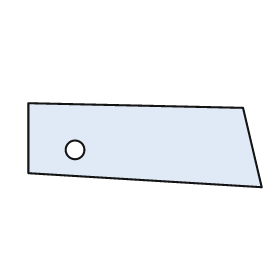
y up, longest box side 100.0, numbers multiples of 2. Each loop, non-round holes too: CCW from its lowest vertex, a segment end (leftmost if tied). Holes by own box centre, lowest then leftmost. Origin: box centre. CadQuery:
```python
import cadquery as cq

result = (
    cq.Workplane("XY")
    .moveTo(50.0, -18.0)
    .lineTo(42.0, 16.0)
    .lineTo(-50.0, 18.0)
    .lineTo(-50.0, -12.0)
    .close()
    .moveTo(-30.0, -2.0)
    .circle(4.0)
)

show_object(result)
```